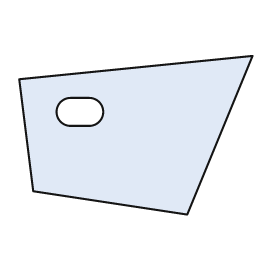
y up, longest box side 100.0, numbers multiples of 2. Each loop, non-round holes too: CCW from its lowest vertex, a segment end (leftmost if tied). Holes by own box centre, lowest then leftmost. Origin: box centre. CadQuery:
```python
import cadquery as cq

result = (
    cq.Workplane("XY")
    .moveTo(22.0, -34.0)
    .lineTo(50.0, 34.0)
    .lineTo(-50.0, 24.0)
    .lineTo(-44.0, -24.0)
    .close()
    .moveTo(-28.0, 4.0)
    .lineTo(-20.0, 4.0)
    .threePointArc((-14.0, 10.0), (-20.0, 16.0))
    .lineTo(-28.0, 16.0)
    .threePointArc((-34.0, 10.0), (-28.0, 4.0))
    .close()
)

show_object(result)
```